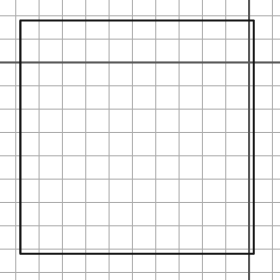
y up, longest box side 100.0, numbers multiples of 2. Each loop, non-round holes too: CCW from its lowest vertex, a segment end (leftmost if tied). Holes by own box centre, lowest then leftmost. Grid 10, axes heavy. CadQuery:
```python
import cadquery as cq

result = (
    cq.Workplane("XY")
    .moveTo(-98.0, -82.0)
    .lineTo(2.0, -82.0)
    .lineTo(2.0, 18.0)
    .lineTo(-98.0, 18.0)
    .close()
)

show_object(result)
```